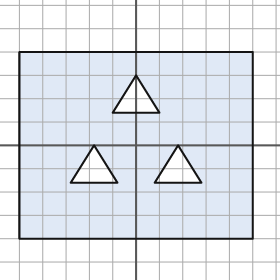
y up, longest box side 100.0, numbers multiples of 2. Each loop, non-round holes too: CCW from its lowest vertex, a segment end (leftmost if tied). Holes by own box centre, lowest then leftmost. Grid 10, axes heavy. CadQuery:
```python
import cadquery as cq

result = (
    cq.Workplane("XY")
    .moveTo(-50.0, -40.0)
    .lineTo(50.0, -40.0)
    .lineTo(50.0, 40.0)
    .lineTo(-50.0, 40.0)
    .close()
    .moveTo(-28.0, -16.0)
    .lineTo(-8.0, -16.0)
    .lineTo(-18.0, 0.0)
    .close()
    .moveTo(8.0, -16.0)
    .lineTo(28.0, -16.0)
    .lineTo(18.0, 0.0)
    .close()
    .moveTo(-10.0, 14.0)
    .lineTo(10.0, 14.0)
    .lineTo(0.0, 30.0)
    .close()
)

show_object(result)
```